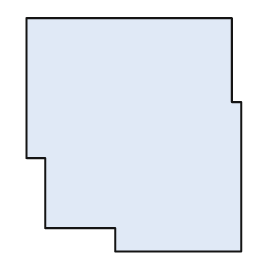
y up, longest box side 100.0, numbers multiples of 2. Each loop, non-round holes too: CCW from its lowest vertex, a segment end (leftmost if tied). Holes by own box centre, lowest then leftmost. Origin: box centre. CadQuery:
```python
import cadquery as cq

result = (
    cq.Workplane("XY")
    .moveTo(-8.0, -50.0)
    .lineTo(46.0, -50.0)
    .lineTo(46.0, 14.0)
    .lineTo(42.0, 14.0)
    .lineTo(42.0, 50.0)
    .lineTo(-46.0, 50.0)
    .lineTo(-46.0, -10.0)
    .lineTo(-38.0, -10.0)
    .lineTo(-38.0, -40.0)
    .lineTo(-8.0, -40.0)
    .close()
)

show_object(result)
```